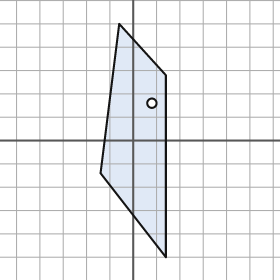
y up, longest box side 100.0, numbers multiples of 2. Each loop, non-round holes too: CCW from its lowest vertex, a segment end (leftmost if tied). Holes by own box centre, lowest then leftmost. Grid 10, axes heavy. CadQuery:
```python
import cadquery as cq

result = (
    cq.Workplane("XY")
    .moveTo(14.0, -50.0)
    .lineTo(14.0, 28.0)
    .lineTo(-6.0, 50.0)
    .lineTo(-14.0, -14.0)
    .close()
    .moveTo(8.0, 16.0)
    .circle(2.0)
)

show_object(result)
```